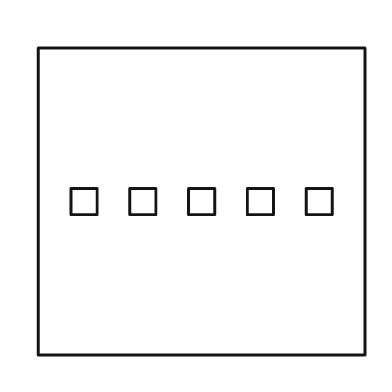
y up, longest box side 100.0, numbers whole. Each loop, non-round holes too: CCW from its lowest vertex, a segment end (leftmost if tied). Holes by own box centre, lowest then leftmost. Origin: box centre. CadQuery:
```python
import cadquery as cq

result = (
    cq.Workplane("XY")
    .moveTo(-50.0, -47.0)
    .lineTo(50.0, -47.0)
    .lineTo(50.0, 47.0)
    .lineTo(-50.0, 47.0)
    .close()
    .moveTo(-40.0, -4.0)
    .lineTo(-32.0, -4.0)
    .lineTo(-32.0, 4.0)
    .lineTo(-40.0, 4.0)
    .close()
    .moveTo(-22.0, -4.0)
    .lineTo(-14.0, -4.0)
    .lineTo(-14.0, 4.0)
    .lineTo(-22.0, 4.0)
    .close()
    .moveTo(-4.0, -4.0)
    .lineTo(4.0, -4.0)
    .lineTo(4.0, 4.0)
    .lineTo(-4.0, 4.0)
    .close()
    .moveTo(14.0, -4.0)
    .lineTo(22.0, -4.0)
    .lineTo(22.0, 4.0)
    .lineTo(14.0, 4.0)
    .close()
    .moveTo(32.0, -4.0)
    .lineTo(40.0, -4.0)
    .lineTo(40.0, 4.0)
    .lineTo(32.0, 4.0)
    .close()
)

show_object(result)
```